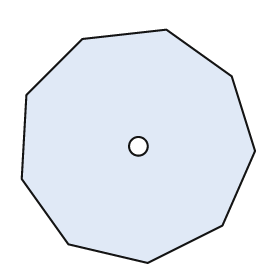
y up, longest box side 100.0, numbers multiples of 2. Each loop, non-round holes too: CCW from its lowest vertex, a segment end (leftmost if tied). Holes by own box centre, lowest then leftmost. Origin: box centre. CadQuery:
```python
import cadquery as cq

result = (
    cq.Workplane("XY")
    .moveTo(4.0, -50.0)
    .lineTo(36.0, -34.0)
    .lineTo(50.0, -2.0)
    .lineTo(40.0, 30.0)
    .lineTo(12.0, 50.0)
    .lineTo(-24.0, 46.0)
    .lineTo(-48.0, 22.0)
    .lineTo(-50.0, -14.0)
    .lineTo(-30.0, -42.0)
    .close()
    .moveTo(0.0, 0.0)
    .circle(4.0)
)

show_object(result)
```